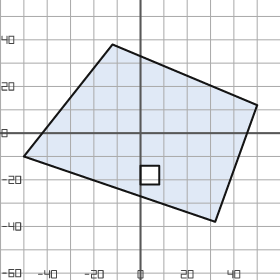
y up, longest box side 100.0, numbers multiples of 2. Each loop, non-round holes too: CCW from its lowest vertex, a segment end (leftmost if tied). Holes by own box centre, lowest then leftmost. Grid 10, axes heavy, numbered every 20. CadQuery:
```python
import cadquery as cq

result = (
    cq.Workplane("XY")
    .moveTo(32.0, -38.0)
    .lineTo(50.0, 12.0)
    .lineTo(-12.0, 38.0)
    .lineTo(-50.0, -10.0)
    .close()
    .moveTo(0.0, -22.0)
    .lineTo(8.0, -22.0)
    .lineTo(8.0, -14.0)
    .lineTo(0.0, -14.0)
    .close()
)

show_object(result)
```